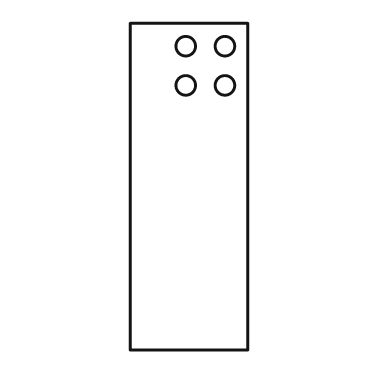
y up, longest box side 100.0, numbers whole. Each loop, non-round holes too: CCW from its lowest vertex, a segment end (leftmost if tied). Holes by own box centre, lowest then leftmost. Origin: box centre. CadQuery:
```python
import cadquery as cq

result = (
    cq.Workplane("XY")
    .moveTo(-18.0, -50.0)
    .lineTo(18.0, -50.0)
    .lineTo(18.0, 50.0)
    .lineTo(-18.0, 50.0)
    .close()
    .moveTo(-1.0, 31.0)
    .circle(3.0)
    .moveTo(11.0, 31.0)
    .circle(3.0)
    .moveTo(-1.0, 43.0)
    .circle(3.0)
    .moveTo(11.0, 43.0)
    .circle(3.0)
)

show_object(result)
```